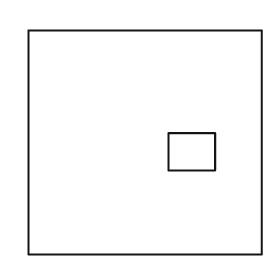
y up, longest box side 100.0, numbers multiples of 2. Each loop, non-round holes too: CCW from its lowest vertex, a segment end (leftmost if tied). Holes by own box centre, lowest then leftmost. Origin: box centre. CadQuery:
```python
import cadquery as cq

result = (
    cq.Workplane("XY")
    .moveTo(-50.0, -48.0)
    .lineTo(50.0, -48.0)
    .lineTo(50.0, 48.0)
    .lineTo(-50.0, 48.0)
    .close()
    .moveTo(10.0, -12.0)
    .lineTo(30.0, -12.0)
    .lineTo(30.0, 4.0)
    .lineTo(10.0, 4.0)
    .close()
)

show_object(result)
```